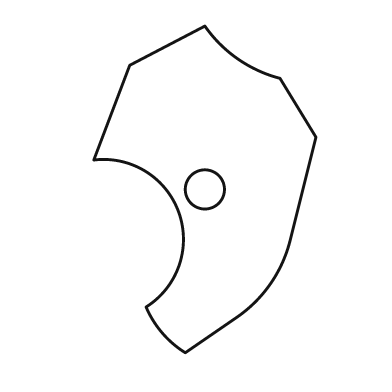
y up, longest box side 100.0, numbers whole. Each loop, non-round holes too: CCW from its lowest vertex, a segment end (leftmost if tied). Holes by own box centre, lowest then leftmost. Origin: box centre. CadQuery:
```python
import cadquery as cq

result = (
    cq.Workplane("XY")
    .moveTo(-6.0, -50.0)
    .lineTo(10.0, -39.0)
    .threePointArc((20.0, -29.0), (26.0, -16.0))
    .lineTo(34.0, 16.0)
    .lineTo(23.0, 34.0)
    .threePointArc((10.0, 40.0), (0.0, 50.0))
    .lineTo(-23.0, 38.0)
    .lineTo(-34.0, 9.0)
    .threePointArc((-8.0, -7.0), (-18.0, -36.0))
    .threePointArc((-13.0, -44.0), (-6.0, -50.0))
    .close()
    .moveTo(0.0, 0.0)
    .circle(6.0)
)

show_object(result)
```